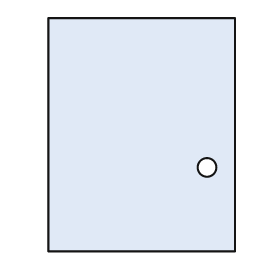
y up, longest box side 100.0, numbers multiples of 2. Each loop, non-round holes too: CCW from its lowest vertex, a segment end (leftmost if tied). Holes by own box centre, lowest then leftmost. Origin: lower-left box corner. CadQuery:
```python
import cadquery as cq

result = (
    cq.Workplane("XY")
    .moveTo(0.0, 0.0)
    .lineTo(80.0, 0.0)
    .lineTo(80.0, 100.0)
    .lineTo(0.0, 100.0)
    .close()
    .moveTo(68.0, 36.0)
    .circle(4.0)
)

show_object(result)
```